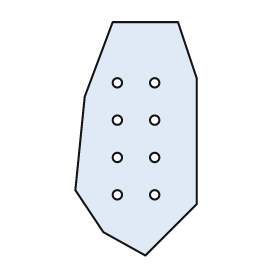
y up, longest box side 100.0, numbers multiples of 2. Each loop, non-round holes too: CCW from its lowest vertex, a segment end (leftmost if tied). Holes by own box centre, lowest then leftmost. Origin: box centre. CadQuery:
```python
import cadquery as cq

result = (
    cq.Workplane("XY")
    .moveTo(4.0, -50.0)
    .lineTo(26.0, -28.0)
    .lineTo(26.0, 26.0)
    .lineTo(18.0, 50.0)
    .lineTo(-10.0, 50.0)
    .lineTo(-22.0, 18.0)
    .lineTo(-26.0, -22.0)
    .lineTo(-14.0, -40.0)
    .close()
    .moveTo(-8.0, -24.0)
    .circle(2.0)
    .moveTo(8.0, -24.0)
    .circle(2.0)
    .moveTo(-8.0, -8.0)
    .circle(2.0)
    .moveTo(8.0, -8.0)
    .circle(2.0)
    .moveTo(-8.0, 8.0)
    .circle(2.0)
    .moveTo(8.0, 8.0)
    .circle(2.0)
    .moveTo(-8.0, 24.0)
    .circle(2.0)
    .moveTo(8.0, 24.0)
    .circle(2.0)
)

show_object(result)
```